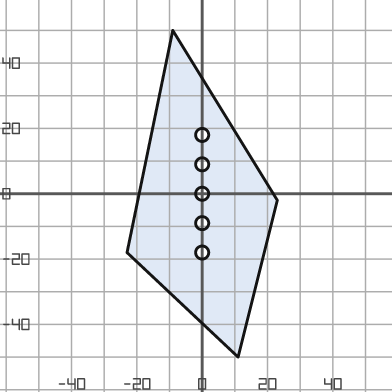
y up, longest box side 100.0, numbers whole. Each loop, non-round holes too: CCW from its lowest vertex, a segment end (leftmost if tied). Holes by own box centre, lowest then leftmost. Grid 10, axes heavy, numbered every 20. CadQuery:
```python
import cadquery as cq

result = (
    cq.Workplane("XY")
    .moveTo(11.0, -50.0)
    .lineTo(23.0, -2.0)
    .lineTo(-9.0, 50.0)
    .lineTo(-23.0, -18.0)
    .close()
    .moveTo(0.0, -18.0)
    .circle(2.0)
    .moveTo(0.0, -9.0)
    .circle(2.0)
    .moveTo(0.0, 0.0)
    .circle(2.0)
    .moveTo(0.0, 9.0)
    .circle(2.0)
    .moveTo(0.0, 18.0)
    .circle(2.0)
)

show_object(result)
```